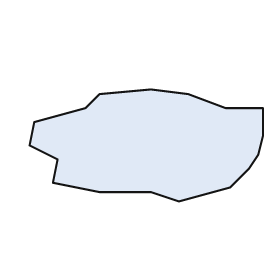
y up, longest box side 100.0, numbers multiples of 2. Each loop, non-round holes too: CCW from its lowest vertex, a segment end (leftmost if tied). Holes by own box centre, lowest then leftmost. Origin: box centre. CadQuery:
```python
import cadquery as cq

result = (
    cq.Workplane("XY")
    .moveTo(14.0, -24.0)
    .lineTo(36.0, -18.0)
    .lineTo(44.0, -10.0)
    .lineTo(48.0, -4.0)
    .lineTo(50.0, 4.0)
    .lineTo(50.0, 16.0)
    .lineTo(34.0, 16.0)
    .lineTo(18.0, 22.0)
    .lineTo(2.0, 24.0)
    .lineTo(-20.0, 22.0)
    .lineTo(-26.0, 16.0)
    .lineTo(-48.0, 10.0)
    .lineTo(-50.0, 0.0)
    .lineTo(-38.0, -6.0)
    .lineTo(-40.0, -16.0)
    .lineTo(-20.0, -20.0)
    .lineTo(2.0, -20.0)
    .close()
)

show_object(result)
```